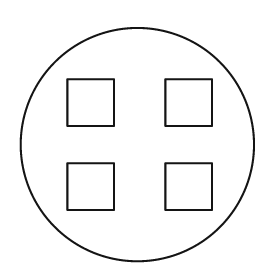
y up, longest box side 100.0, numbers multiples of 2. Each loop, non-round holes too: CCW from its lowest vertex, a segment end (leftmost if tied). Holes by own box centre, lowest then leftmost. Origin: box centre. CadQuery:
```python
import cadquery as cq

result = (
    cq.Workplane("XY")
    .moveTo(0.0, 0.0)
    .circle(50.0)
    .moveTo(-30.0, -28.0)
    .lineTo(-10.0, -28.0)
    .lineTo(-10.0, -8.0)
    .lineTo(-30.0, -8.0)
    .close()
    .moveTo(12.0, -28.0)
    .lineTo(32.0, -28.0)
    .lineTo(32.0, -8.0)
    .lineTo(12.0, -8.0)
    .close()
    .moveTo(-30.0, 8.0)
    .lineTo(-10.0, 8.0)
    .lineTo(-10.0, 28.0)
    .lineTo(-30.0, 28.0)
    .close()
    .moveTo(12.0, 8.0)
    .lineTo(32.0, 8.0)
    .lineTo(32.0, 28.0)
    .lineTo(12.0, 28.0)
    .close()
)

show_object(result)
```